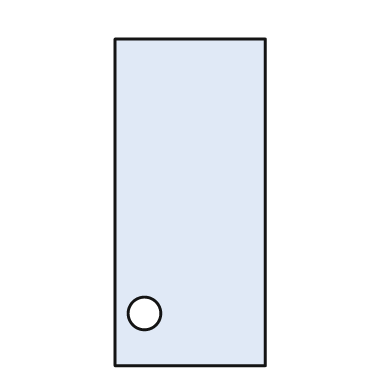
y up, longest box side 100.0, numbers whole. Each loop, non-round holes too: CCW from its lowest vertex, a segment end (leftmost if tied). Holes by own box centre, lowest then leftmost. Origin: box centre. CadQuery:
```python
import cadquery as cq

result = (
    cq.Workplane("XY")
    .moveTo(-23.0, -50.0)
    .lineTo(23.0, -50.0)
    .lineTo(23.0, 50.0)
    .lineTo(-23.0, 50.0)
    .close()
    .moveTo(-14.0, -34.0)
    .circle(5.0)
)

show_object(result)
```